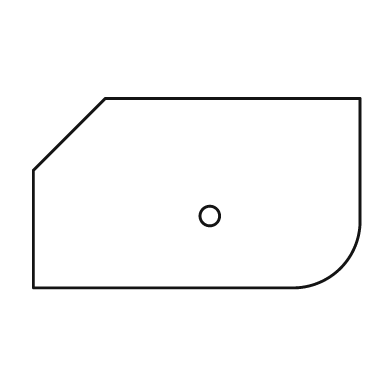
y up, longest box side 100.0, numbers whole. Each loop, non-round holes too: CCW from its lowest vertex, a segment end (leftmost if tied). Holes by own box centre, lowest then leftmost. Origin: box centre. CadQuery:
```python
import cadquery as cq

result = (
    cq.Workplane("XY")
    .moveTo(-50.0, -29.0)
    .lineTo(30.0, -29.0)
    .threePointArc((44.0, -23.0), (50.0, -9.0))
    .lineTo(50.0, 29.0)
    .lineTo(-28.0, 29.0)
    .lineTo(-50.0, 7.0)
    .close()
    .moveTo(4.0, -7.0)
    .circle(3.0)
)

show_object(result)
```